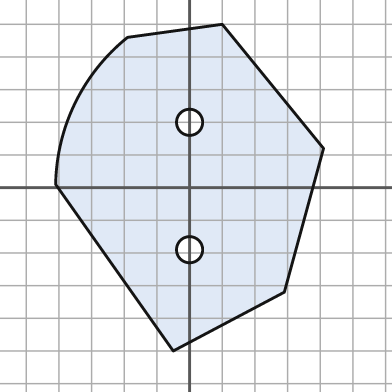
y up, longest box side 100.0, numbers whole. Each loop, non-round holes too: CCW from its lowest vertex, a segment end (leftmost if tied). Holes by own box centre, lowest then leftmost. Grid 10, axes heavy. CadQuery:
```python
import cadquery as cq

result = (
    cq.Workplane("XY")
    .moveTo(-5.0, -50.0)
    .lineTo(29.0, -32.0)
    .lineTo(41.0, 12.0)
    .lineTo(10.0, 50.0)
    .lineTo(-19.0, 46.0)
    .threePointArc((-35.0, 26.0), (-41.0, 1.0))
    .close()
    .moveTo(0.0, -19.0)
    .circle(4.0)
    .moveTo(0.0, 20.0)
    .circle(4.0)
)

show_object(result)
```